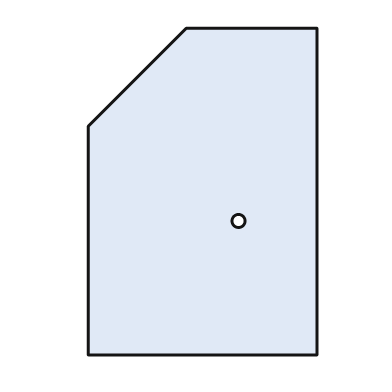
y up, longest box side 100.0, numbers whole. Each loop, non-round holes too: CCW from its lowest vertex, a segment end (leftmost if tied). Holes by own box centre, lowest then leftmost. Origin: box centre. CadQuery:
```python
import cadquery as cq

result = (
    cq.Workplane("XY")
    .moveTo(-35.0, -50.0)
    .lineTo(35.0, -50.0)
    .lineTo(35.0, 50.0)
    .lineTo(-5.0, 50.0)
    .lineTo(-35.0, 20.0)
    .close()
    .moveTo(11.0, -9.0)
    .circle(2.0)
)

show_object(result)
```